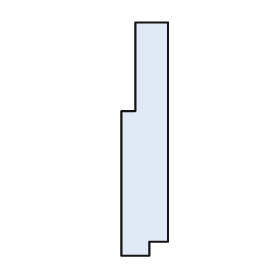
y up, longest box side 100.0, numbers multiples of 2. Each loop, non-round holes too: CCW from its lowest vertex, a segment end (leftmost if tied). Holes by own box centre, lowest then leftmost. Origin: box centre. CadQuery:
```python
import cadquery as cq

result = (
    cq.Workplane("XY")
    .moveTo(-10.0, -50.0)
    .lineTo(2.0, -50.0)
    .lineTo(2.0, -44.0)
    .lineTo(10.0, -44.0)
    .lineTo(10.0, 50.0)
    .lineTo(-4.0, 50.0)
    .lineTo(-4.0, 12.0)
    .lineTo(-10.0, 12.0)
    .close()
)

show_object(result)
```